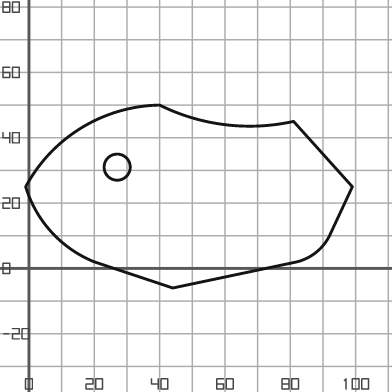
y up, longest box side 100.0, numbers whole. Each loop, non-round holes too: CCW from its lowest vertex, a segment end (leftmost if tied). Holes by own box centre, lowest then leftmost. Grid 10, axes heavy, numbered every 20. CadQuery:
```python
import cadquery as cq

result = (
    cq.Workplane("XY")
    .moveTo(44.0, -6.0)
    .lineTo(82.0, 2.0)
    .threePointArc((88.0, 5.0), (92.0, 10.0))
    .lineTo(99.0, 25.0)
    .lineTo(81.0, 45.0)
    .threePointArc((60.0, 44.0), (40.0, 50.0))
    .threePointArc((16.0, 43.0), (-1.0, 25.0))
    .threePointArc((7.0, 11.0), (20.0, 2.0))
    .close()
    .moveTo(27.0, 31.0)
    .circle(4.0)
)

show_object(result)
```